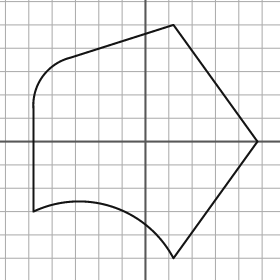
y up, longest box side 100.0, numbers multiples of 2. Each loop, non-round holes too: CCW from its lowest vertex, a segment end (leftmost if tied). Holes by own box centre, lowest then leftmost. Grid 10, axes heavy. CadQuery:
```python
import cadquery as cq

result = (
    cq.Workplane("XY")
    .moveTo(12.0, -50.0)
    .lineTo(48.0, 0.0)
    .lineTo(12.0, 50.0)
    .lineTo(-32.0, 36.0)
    .threePointArc((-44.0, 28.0), (-48.0, 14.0))
    .lineTo(-48.0, -30.0)
    .threePointArc((-14.0, -28.0), (12.0, -50.0))
    .close()
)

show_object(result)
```